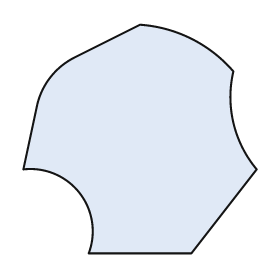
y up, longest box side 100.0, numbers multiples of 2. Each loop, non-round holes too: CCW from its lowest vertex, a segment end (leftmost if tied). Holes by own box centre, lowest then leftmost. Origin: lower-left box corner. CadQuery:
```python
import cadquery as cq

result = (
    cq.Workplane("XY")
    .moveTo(28.0, 0.0)
    .lineTo(72.0, 0.0)
    .lineTo(100.0, 36.0)
    .threePointArc((90.0, 56.0), (90.0, 78.0))
    .threePointArc((72.0, 92.0), (50.0, 98.0))
    .lineTo(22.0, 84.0)
    .threePointArc((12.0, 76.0), (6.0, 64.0))
    .lineTo(0.0, 36.0)
    .threePointArc((24.0, 26.0), (28.0, 0.0))
    .close()
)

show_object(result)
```